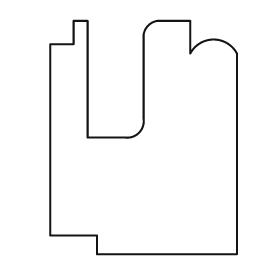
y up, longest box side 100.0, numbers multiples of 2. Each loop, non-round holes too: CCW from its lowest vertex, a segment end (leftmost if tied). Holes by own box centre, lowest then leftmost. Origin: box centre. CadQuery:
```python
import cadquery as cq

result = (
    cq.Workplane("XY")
    .moveTo(-20.0, -50.0)
    .lineTo(40.0, -50.0)
    .lineTo(40.0, 36.0)
    .threePointArc((30.0, 42.0), (20.0, 36.0))
    .lineTo(20.0, 50.0)
    .lineTo(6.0, 50.0)
    .threePointArc((2.0, 48.0), (0.0, 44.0))
    .lineTo(0.0, 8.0)
    .threePointArc((-2.0, 2.0), (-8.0, 0.0))
    .lineTo(-24.0, 0.0)
    .lineTo(-24.0, 50.0)
    .lineTo(-30.0, 50.0)
    .lineTo(-30.0, 40.0)
    .lineTo(-40.0, 40.0)
    .lineTo(-40.0, -42.0)
    .lineTo(-20.0, -42.0)
    .close()
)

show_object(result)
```